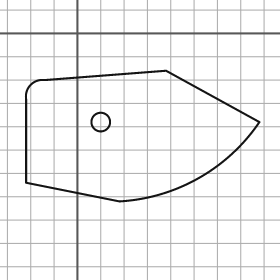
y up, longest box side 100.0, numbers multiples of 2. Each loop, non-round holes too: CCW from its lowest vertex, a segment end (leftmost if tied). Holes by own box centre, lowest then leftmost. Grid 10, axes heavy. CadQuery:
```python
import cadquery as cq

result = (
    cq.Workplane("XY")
    .moveTo(18.0, -72.0)
    .threePointArc((52.0, -62.0), (78.0, -38.0))
    .lineTo(38.0, -16.0)
    .lineTo(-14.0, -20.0)
    .threePointArc((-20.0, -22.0), (-22.0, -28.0))
    .lineTo(-22.0, -64.0)
    .close()
    .moveTo(10.0, -38.0)
    .circle(4.0)
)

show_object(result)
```